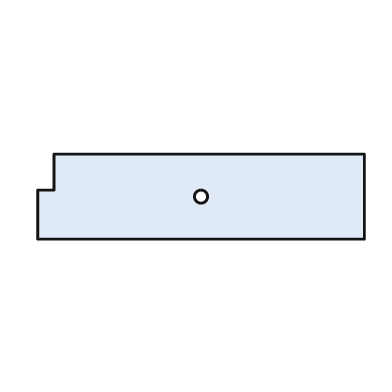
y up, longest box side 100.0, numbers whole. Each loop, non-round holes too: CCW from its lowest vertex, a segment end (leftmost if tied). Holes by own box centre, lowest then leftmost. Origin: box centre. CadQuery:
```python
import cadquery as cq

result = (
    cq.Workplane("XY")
    .moveTo(-50.0, -13.0)
    .lineTo(50.0, -13.0)
    .lineTo(50.0, 13.0)
    .lineTo(-45.0, 13.0)
    .lineTo(-45.0, 2.0)
    .lineTo(-50.0, 2.0)
    .close()
    .moveTo(0.0, 0.0)
    .circle(2.0)
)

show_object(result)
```